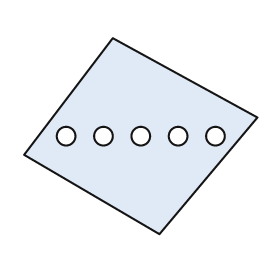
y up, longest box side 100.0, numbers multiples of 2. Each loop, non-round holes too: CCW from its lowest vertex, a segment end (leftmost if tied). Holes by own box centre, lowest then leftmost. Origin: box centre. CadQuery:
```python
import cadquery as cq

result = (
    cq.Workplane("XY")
    .moveTo(8.0, -42.0)
    .lineTo(50.0, 8.0)
    .lineTo(-12.0, 42.0)
    .lineTo(-50.0, -8.0)
    .close()
    .moveTo(-32.0, 0.0)
    .circle(4.0)
    .moveTo(-16.0, 0.0)
    .circle(4.0)
    .moveTo(0.0, 0.0)
    .circle(4.0)
    .moveTo(16.0, 0.0)
    .circle(4.0)
    .moveTo(32.0, 0.0)
    .circle(4.0)
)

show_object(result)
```